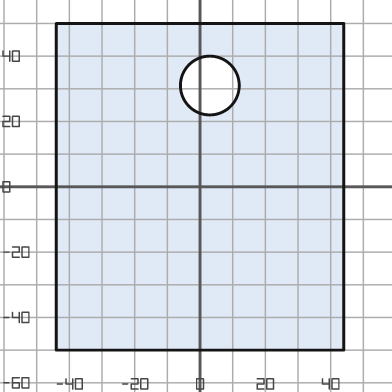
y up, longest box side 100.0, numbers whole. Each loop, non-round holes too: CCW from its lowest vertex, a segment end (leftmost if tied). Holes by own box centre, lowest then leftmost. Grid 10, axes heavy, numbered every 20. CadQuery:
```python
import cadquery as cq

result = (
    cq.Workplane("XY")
    .moveTo(-44.0, -50.0)
    .lineTo(44.0, -50.0)
    .lineTo(44.0, 50.0)
    .lineTo(-44.0, 50.0)
    .close()
    .moveTo(3.0, 31.0)
    .circle(9.0)
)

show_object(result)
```